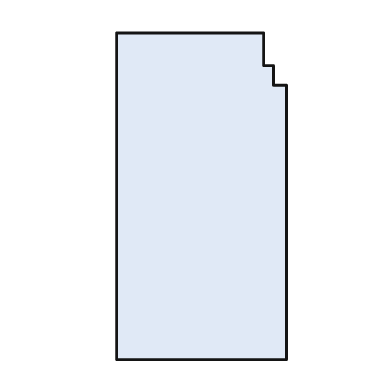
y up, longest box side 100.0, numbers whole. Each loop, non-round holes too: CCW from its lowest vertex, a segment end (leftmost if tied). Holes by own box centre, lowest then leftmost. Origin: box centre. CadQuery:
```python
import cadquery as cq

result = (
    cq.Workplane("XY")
    .moveTo(-26.0, -50.0)
    .lineTo(26.0, -50.0)
    .lineTo(26.0, 34.0)
    .lineTo(22.0, 34.0)
    .lineTo(22.0, 40.0)
    .lineTo(19.0, 40.0)
    .lineTo(19.0, 50.0)
    .lineTo(-26.0, 50.0)
    .close()
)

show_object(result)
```